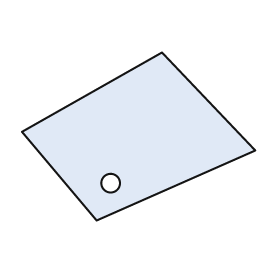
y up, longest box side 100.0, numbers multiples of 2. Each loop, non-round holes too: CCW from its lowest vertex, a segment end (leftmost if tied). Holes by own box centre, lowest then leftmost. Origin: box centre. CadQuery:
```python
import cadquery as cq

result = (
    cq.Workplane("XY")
    .moveTo(-18.0, -36.0)
    .lineTo(50.0, -6.0)
    .lineTo(10.0, 36.0)
    .lineTo(-50.0, 2.0)
    .close()
    .moveTo(-12.0, -20.0)
    .circle(4.0)
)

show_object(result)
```